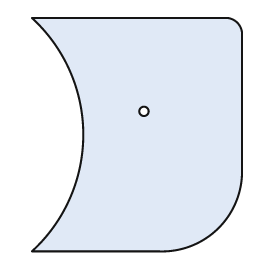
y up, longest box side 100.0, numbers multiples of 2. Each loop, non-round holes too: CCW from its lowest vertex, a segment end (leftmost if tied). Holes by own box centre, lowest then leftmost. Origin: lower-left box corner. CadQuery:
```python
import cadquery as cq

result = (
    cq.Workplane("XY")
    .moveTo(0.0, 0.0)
    .lineTo(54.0, 0.0)
    .threePointArc((80.0, 10.0), (90.0, 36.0))
    .lineTo(90.0, 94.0)
    .threePointArc((88.0, 98.0), (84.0, 100.0))
    .lineTo(0.0, 100.0)
    .threePointArc((22.0, 50.0), (0.0, 0.0))
    .close()
    .moveTo(48.0, 60.0)
    .circle(2.0)
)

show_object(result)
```